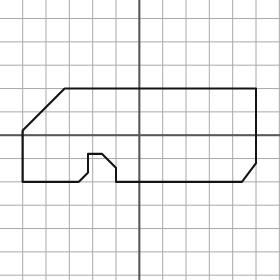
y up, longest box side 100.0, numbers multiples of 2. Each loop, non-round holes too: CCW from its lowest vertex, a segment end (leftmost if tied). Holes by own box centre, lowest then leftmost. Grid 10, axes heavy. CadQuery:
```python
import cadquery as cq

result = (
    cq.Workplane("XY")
    .moveTo(-50.0, -20.0)
    .lineTo(-26.0, -20.0)
    .lineTo(-22.0, -16.0)
    .lineTo(-22.0, -8.0)
    .lineTo(-16.0, -8.0)
    .lineTo(-10.0, -14.0)
    .lineTo(-10.0, -20.0)
    .lineTo(44.0, -20.0)
    .lineTo(50.0, -12.0)
    .lineTo(50.0, 20.0)
    .lineTo(-32.0, 20.0)
    .lineTo(-50.0, 2.0)
    .close()
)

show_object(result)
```